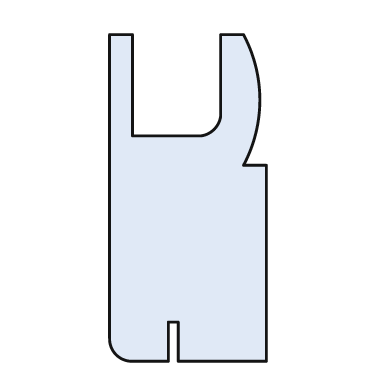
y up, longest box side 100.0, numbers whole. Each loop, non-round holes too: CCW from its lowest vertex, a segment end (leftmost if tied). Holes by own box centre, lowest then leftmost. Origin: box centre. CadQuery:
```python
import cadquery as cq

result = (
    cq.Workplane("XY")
    .moveTo(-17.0, -50.0)
    .lineTo(-6.0, -50.0)
    .lineTo(-6.0, -38.0)
    .lineTo(-3.0, -38.0)
    .lineTo(-3.0, -50.0)
    .lineTo(24.0, -50.0)
    .lineTo(24.0, 10.0)
    .lineTo(17.0, 10.0)
    .threePointArc((22.0, 30.0), (17.0, 50.0))
    .lineTo(10.0, 50.0)
    .lineTo(10.0, 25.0)
    .threePointArc((8.0, 21.0), (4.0, 19.0))
    .lineTo(-17.0, 19.0)
    .lineTo(-17.0, 50.0)
    .lineTo(-24.0, 50.0)
    .lineTo(-24.0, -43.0)
    .threePointArc((-22.0, -48.0), (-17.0, -50.0))
    .close()
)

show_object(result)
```